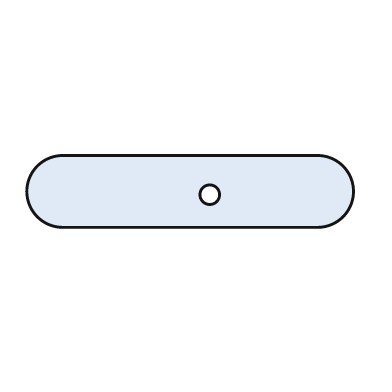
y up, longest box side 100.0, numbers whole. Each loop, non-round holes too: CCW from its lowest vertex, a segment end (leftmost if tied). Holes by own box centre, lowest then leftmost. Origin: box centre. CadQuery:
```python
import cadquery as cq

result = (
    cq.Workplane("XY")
    .moveTo(-39.0, -11.0)
    .lineTo(39.0, -11.0)
    .threePointArc((50.0, 0.0), (39.0, 11.0))
    .lineTo(-39.0, 11.0)
    .threePointArc((-50.0, 0.0), (-39.0, -11.0))
    .close()
    .moveTo(6.0, -1.0)
    .circle(3.0)
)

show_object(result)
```